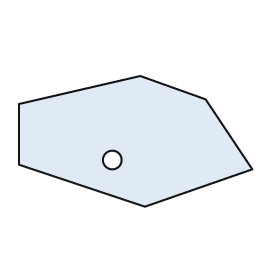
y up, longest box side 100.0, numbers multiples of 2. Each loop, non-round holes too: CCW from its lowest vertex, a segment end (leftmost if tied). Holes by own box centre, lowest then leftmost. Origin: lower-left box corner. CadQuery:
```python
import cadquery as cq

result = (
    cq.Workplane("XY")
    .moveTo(54.0, 0.0)
    .lineTo(100.0, 16.0)
    .lineTo(80.0, 46.0)
    .lineTo(52.0, 56.0)
    .lineTo(0.0, 44.0)
    .lineTo(0.0, 18.0)
    .close()
    .moveTo(40.0, 20.0)
    .circle(4.0)
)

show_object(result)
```